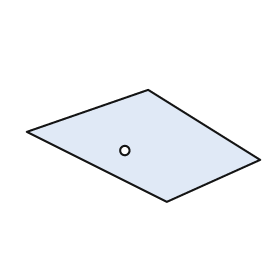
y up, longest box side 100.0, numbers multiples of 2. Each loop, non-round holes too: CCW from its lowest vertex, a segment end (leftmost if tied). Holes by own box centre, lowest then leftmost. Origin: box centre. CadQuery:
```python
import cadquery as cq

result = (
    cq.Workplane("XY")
    .moveTo(10.0, -24.0)
    .lineTo(50.0, -6.0)
    .lineTo(2.0, 24.0)
    .lineTo(-50.0, 6.0)
    .close()
    .moveTo(-8.0, -2.0)
    .circle(2.0)
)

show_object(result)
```